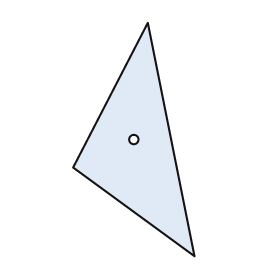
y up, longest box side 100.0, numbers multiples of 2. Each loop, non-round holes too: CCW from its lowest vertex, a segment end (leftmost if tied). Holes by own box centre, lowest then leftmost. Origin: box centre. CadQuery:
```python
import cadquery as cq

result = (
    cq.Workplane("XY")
    .moveTo(26.0, -50.0)
    .lineTo(6.0, 50.0)
    .lineTo(-26.0, -12.0)
    .close()
    .moveTo(0.0, 0.0)
    .circle(2.0)
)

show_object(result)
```